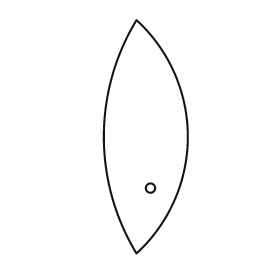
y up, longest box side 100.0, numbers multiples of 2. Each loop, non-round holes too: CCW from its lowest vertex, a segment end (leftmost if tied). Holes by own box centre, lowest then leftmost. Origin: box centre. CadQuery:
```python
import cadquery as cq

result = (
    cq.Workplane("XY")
    .moveTo(-4.0, -50.0)
    .threePointArc((18.0, 0.0), (-4.0, 50.0))
    .threePointArc((-18.0, 0.0), (-4.0, -50.0))
    .close()
    .moveTo(2.0, -22.0)
    .circle(2.0)
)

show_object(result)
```